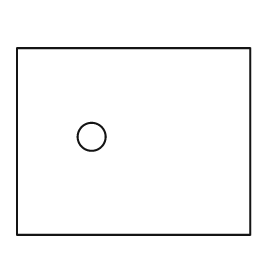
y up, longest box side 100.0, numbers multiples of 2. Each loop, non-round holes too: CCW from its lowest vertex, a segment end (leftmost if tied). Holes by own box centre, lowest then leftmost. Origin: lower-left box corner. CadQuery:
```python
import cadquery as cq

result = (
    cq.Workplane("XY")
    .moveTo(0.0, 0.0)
    .lineTo(100.0, 0.0)
    .lineTo(100.0, 80.0)
    .lineTo(0.0, 80.0)
    .close()
    .moveTo(32.0, 42.0)
    .circle(6.0)
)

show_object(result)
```